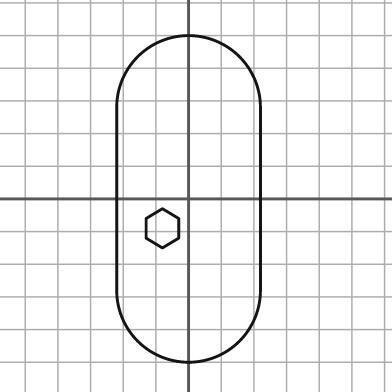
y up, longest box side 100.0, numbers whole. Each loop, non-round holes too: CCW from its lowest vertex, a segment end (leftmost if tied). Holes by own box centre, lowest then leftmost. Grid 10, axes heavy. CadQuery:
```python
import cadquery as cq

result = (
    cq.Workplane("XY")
    .moveTo(-22.0, -28.0)
    .threePointArc((0.0, -50.0), (22.0, -28.0))
    .lineTo(22.0, 28.0)
    .threePointArc((0.0, 50.0), (-22.0, 28.0))
    .close()
    .moveTo(-8.0, -15.0)
    .lineTo(-3.0, -12.0)
    .lineTo(-3.0, -6.0)
    .lineTo(-8.0, -3.0)
    .lineTo(-13.0, -6.0)
    .lineTo(-13.0, -12.0)
    .close()
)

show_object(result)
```